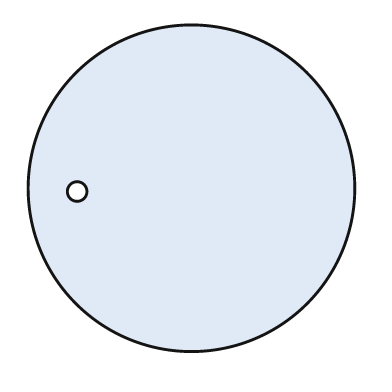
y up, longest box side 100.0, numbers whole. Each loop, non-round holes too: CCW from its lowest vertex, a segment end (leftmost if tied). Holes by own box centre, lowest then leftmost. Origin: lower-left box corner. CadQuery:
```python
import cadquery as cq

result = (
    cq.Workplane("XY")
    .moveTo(50.0, 50.0)
    .circle(50.0)
    .moveTo(15.0, 49.0)
    .circle(3.0)
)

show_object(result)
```